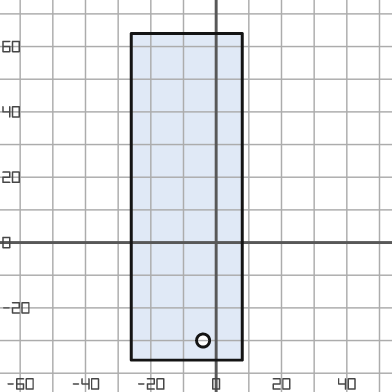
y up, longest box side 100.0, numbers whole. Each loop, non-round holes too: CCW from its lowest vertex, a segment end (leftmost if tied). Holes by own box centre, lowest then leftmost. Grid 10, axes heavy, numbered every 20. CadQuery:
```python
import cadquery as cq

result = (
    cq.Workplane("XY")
    .moveTo(-26.0, -36.0)
    .lineTo(8.0, -36.0)
    .lineTo(8.0, 64.0)
    .lineTo(-26.0, 64.0)
    .close()
    .moveTo(-4.0, -30.0)
    .circle(2.0)
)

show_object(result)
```